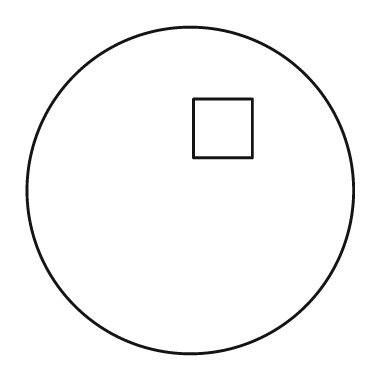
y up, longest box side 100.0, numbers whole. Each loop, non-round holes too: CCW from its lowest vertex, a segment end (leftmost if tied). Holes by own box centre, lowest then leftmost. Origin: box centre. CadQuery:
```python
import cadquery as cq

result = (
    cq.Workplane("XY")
    .moveTo(0.0, 0.0)
    .circle(50.0)
    .moveTo(1.0, 10.0)
    .lineTo(19.0, 10.0)
    .lineTo(19.0, 28.0)
    .lineTo(1.0, 28.0)
    .close()
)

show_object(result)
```